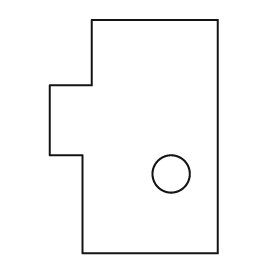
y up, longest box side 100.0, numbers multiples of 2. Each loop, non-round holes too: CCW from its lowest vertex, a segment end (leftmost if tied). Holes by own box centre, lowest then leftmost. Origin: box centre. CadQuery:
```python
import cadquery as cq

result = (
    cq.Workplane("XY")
    .moveTo(-22.0, -50.0)
    .lineTo(36.0, -50.0)
    .lineTo(36.0, 50.0)
    .lineTo(-18.0, 50.0)
    .lineTo(-18.0, 22.0)
    .lineTo(-36.0, 22.0)
    .lineTo(-36.0, -8.0)
    .lineTo(-22.0, -8.0)
    .close()
    .moveTo(16.0, -16.0)
    .circle(8.0)
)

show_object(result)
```